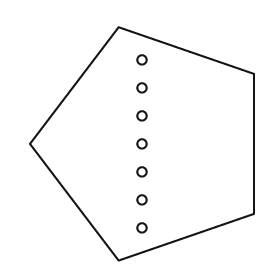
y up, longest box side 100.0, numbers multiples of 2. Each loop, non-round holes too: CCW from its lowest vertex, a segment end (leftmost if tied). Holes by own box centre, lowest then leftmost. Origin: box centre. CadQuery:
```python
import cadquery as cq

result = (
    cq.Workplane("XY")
    .moveTo(-10.0, -50.0)
    .lineTo(48.0, -30.0)
    .lineTo(48.0, 30.0)
    .lineTo(-10.0, 50.0)
    .lineTo(-48.0, 0.0)
    .close()
    .moveTo(0.0, -36.0)
    .circle(2.0)
    .moveTo(0.0, -24.0)
    .circle(2.0)
    .moveTo(0.0, -12.0)
    .circle(2.0)
    .moveTo(0.0, 0.0)
    .circle(2.0)
    .moveTo(0.0, 12.0)
    .circle(2.0)
    .moveTo(0.0, 24.0)
    .circle(2.0)
    .moveTo(0.0, 36.0)
    .circle(2.0)
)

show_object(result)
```